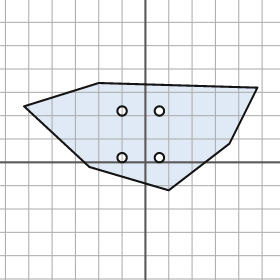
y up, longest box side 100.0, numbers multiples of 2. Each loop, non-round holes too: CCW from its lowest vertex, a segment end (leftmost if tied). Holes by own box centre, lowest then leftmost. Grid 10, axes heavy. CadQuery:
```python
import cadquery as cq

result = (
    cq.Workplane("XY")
    .moveTo(10.0, -12.0)
    .lineTo(36.0, 8.0)
    .lineTo(48.0, 32.0)
    .lineTo(-20.0, 34.0)
    .lineTo(-52.0, 24.0)
    .lineTo(-24.0, -2.0)
    .close()
    .moveTo(-10.0, 2.0)
    .circle(2.0)
    .moveTo(6.0, 2.0)
    .circle(2.0)
    .moveTo(-10.0, 22.0)
    .circle(2.0)
    .moveTo(6.0, 22.0)
    .circle(2.0)
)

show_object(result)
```